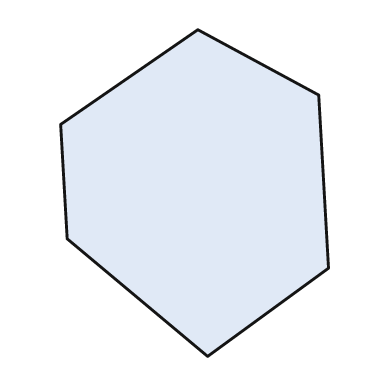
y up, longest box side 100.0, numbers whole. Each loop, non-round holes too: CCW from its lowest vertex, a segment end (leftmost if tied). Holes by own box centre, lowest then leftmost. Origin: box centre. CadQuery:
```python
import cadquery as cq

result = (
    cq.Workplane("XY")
    .moveTo(4.0, -50.0)
    .lineTo(41.0, -23.0)
    .lineTo(38.0, 30.0)
    .lineTo(1.0, 50.0)
    .lineTo(-41.0, 21.0)
    .lineTo(-39.0, -14.0)
    .close()
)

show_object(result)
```